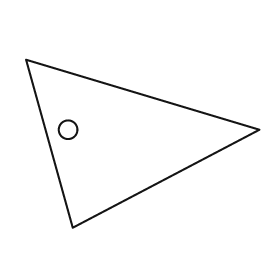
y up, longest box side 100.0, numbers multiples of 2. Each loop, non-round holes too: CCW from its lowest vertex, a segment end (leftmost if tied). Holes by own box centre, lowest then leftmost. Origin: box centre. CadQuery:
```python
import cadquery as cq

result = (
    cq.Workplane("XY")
    .moveTo(-30.0, -36.0)
    .lineTo(50.0, 6.0)
    .lineTo(-50.0, 36.0)
    .close()
    .moveTo(-32.0, 6.0)
    .circle(4.0)
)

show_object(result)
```